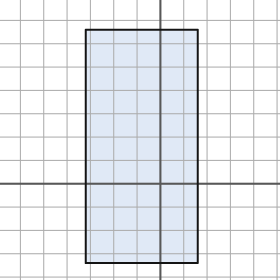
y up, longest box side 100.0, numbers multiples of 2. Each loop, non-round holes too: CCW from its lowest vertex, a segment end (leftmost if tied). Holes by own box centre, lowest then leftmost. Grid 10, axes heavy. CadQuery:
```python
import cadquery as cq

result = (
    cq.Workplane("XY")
    .moveTo(-32.0, -34.0)
    .lineTo(16.0, -34.0)
    .lineTo(16.0, 66.0)
    .lineTo(-32.0, 66.0)
    .close()
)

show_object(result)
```